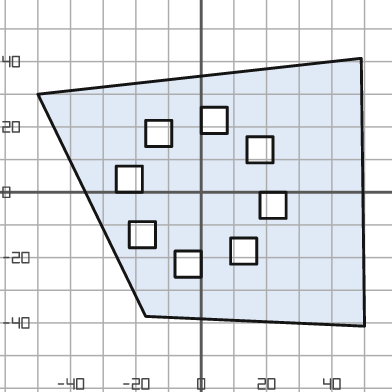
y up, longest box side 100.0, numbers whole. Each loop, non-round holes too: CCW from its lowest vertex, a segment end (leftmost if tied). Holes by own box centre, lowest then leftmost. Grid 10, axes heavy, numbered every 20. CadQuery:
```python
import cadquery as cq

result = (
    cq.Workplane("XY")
    .moveTo(50.0, -41.0)
    .lineTo(49.0, 41.0)
    .lineTo(-50.0, 30.0)
    .lineTo(-17.0, -38.0)
    .close()
    .moveTo(-8.0, -26.0)
    .lineTo(0.0, -26.0)
    .lineTo(0.0, -18.0)
    .lineTo(-8.0, -18.0)
    .close()
    .moveTo(9.0, -22.0)
    .lineTo(17.0, -22.0)
    .lineTo(17.0, -14.0)
    .lineTo(9.0, -14.0)
    .close()
    .moveTo(-22.0, -17.0)
    .lineTo(-14.0, -17.0)
    .lineTo(-14.0, -9.0)
    .lineTo(-22.0, -9.0)
    .close()
    .moveTo(18.0, -8.0)
    .lineTo(26.0, -8.0)
    .lineTo(26.0, 0.0)
    .lineTo(18.0, 0.0)
    .close()
    .moveTo(-26.0, 0.0)
    .lineTo(-18.0, 0.0)
    .lineTo(-18.0, 8.0)
    .lineTo(-26.0, 8.0)
    .close()
    .moveTo(14.0, 9.0)
    .lineTo(22.0, 9.0)
    .lineTo(22.0, 17.0)
    .lineTo(14.0, 17.0)
    .close()
    .moveTo(-17.0, 14.0)
    .lineTo(-9.0, 14.0)
    .lineTo(-9.0, 22.0)
    .lineTo(-17.0, 22.0)
    .close()
    .moveTo(0.0, 18.0)
    .lineTo(8.0, 18.0)
    .lineTo(8.0, 26.0)
    .lineTo(0.0, 26.0)
    .close()
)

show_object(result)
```